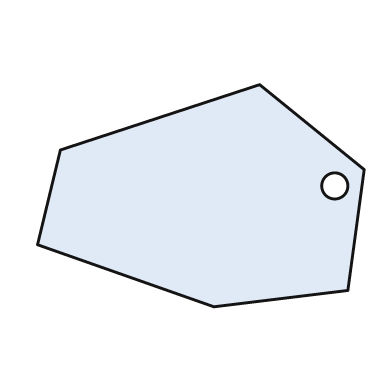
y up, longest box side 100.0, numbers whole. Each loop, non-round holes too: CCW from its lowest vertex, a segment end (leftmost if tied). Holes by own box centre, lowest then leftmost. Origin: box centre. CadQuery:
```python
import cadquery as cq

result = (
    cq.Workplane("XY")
    .moveTo(4.0, -34.0)
    .lineTo(45.0, -29.0)
    .lineTo(50.0, 8.0)
    .lineTo(18.0, 34.0)
    .lineTo(-43.0, 14.0)
    .lineTo(-50.0, -15.0)
    .close()
    .moveTo(41.0, 3.0)
    .circle(4.0)
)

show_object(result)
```